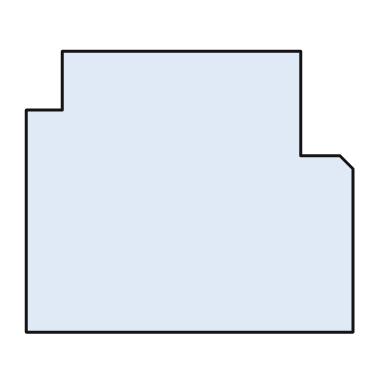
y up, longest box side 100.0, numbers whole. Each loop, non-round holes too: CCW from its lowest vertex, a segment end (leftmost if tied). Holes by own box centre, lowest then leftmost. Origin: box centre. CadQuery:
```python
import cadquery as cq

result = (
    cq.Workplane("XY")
    .moveTo(-50.0, -43.0)
    .lineTo(50.0, -43.0)
    .lineTo(50.0, 7.0)
    .lineTo(46.0, 11.0)
    .lineTo(34.0, 11.0)
    .lineTo(34.0, 43.0)
    .lineTo(-39.0, 43.0)
    .lineTo(-39.0, 25.0)
    .lineTo(-50.0, 25.0)
    .close()
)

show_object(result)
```